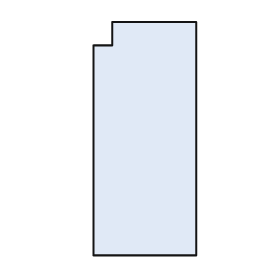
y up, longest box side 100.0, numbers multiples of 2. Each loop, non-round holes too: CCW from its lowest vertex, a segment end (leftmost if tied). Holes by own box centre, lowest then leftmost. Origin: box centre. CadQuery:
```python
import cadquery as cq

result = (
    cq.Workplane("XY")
    .moveTo(-22.0, -50.0)
    .lineTo(22.0, -50.0)
    .lineTo(22.0, 50.0)
    .lineTo(-14.0, 50.0)
    .lineTo(-14.0, 40.0)
    .lineTo(-22.0, 40.0)
    .close()
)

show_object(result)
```